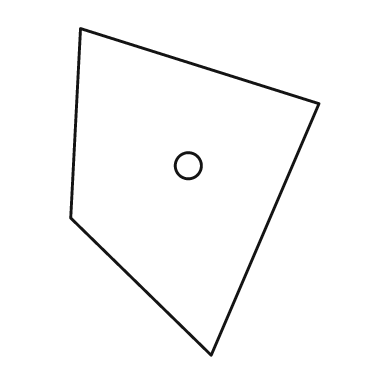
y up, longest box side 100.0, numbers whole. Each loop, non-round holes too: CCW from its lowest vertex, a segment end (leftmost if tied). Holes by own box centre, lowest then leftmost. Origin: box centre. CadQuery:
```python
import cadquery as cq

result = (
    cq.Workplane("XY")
    .moveTo(5.0, -50.0)
    .lineTo(38.0, 27.0)
    .lineTo(-35.0, 50.0)
    .lineTo(-38.0, -8.0)
    .close()
    .moveTo(-2.0, 8.0)
    .circle(4.0)
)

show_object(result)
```